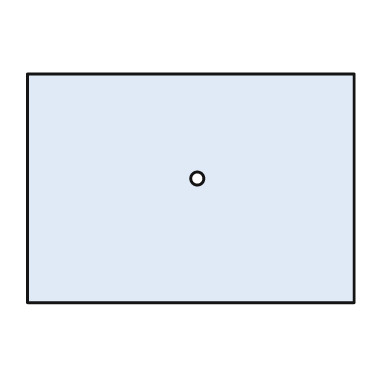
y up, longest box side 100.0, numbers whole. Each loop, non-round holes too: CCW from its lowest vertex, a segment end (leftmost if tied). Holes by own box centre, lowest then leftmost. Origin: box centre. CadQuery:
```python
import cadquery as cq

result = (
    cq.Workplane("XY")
    .moveTo(-50.0, -35.0)
    .lineTo(50.0, -35.0)
    .lineTo(50.0, 35.0)
    .lineTo(-50.0, 35.0)
    .close()
    .moveTo(2.0, 3.0)
    .circle(2.0)
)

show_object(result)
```